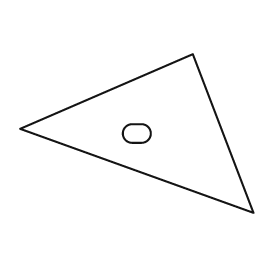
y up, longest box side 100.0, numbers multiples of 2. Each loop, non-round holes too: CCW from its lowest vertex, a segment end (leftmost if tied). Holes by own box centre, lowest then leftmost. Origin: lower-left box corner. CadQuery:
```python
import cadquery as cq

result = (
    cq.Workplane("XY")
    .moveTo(100.0, 0.0)
    .lineTo(74.0, 68.0)
    .lineTo(0.0, 36.0)
    .close()
    .moveTo(48.0, 30.0)
    .lineTo(52.0, 30.0)
    .threePointArc((56.0, 34.0), (52.0, 38.0))
    .lineTo(48.0, 38.0)
    .threePointArc((44.0, 34.0), (48.0, 30.0))
    .close()
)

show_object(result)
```